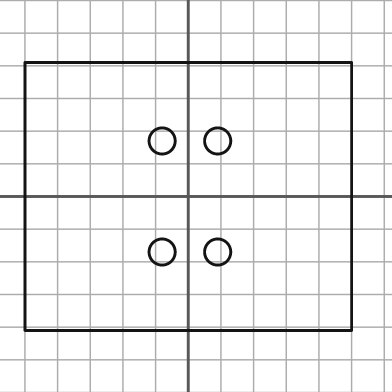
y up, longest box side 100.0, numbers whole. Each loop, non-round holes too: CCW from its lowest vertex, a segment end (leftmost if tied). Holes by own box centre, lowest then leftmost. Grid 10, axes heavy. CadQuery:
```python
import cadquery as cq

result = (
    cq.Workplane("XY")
    .moveTo(-50.0, -41.0)
    .lineTo(50.0, -41.0)
    .lineTo(50.0, 41.0)
    .lineTo(-50.0, 41.0)
    .close()
    .moveTo(-8.0, -17.0)
    .circle(4.0)
    .moveTo(9.0, -17.0)
    .circle(4.0)
    .moveTo(-8.0, 17.0)
    .circle(4.0)
    .moveTo(9.0, 17.0)
    .circle(4.0)
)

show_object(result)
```